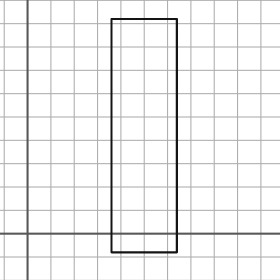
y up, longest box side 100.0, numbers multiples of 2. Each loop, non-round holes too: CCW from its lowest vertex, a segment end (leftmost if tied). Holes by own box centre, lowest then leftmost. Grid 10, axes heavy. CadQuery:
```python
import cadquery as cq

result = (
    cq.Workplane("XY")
    .moveTo(36.0, -8.0)
    .lineTo(64.0, -8.0)
    .lineTo(64.0, 92.0)
    .lineTo(36.0, 92.0)
    .close()
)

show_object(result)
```